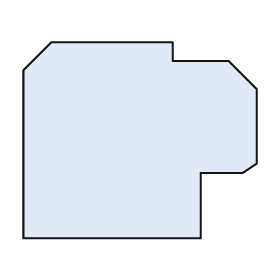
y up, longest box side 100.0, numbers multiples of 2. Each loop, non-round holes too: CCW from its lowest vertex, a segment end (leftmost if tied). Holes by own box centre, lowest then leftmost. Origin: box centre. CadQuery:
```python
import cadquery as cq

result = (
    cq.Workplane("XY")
    .moveTo(-50.0, -42.0)
    .lineTo(26.0, -42.0)
    .lineTo(26.0, -14.0)
    .lineTo(44.0, -14.0)
    .lineTo(50.0, -10.0)
    .lineTo(50.0, 22.0)
    .lineTo(38.0, 34.0)
    .lineTo(14.0, 34.0)
    .lineTo(14.0, 42.0)
    .lineTo(-38.0, 42.0)
    .lineTo(-50.0, 30.0)
    .close()
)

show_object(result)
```